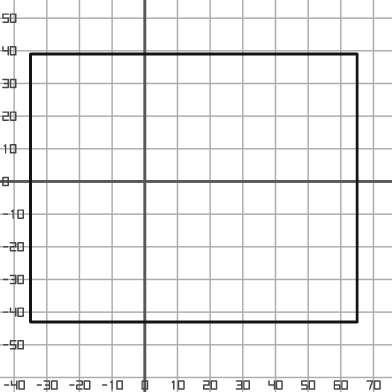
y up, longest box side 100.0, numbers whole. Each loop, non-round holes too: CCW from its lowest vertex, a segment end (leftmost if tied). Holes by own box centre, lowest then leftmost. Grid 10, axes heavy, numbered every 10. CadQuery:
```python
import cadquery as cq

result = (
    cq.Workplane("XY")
    .moveTo(-35.0, -43.0)
    .lineTo(65.0, -43.0)
    .lineTo(65.0, 39.0)
    .lineTo(-35.0, 39.0)
    .close()
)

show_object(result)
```